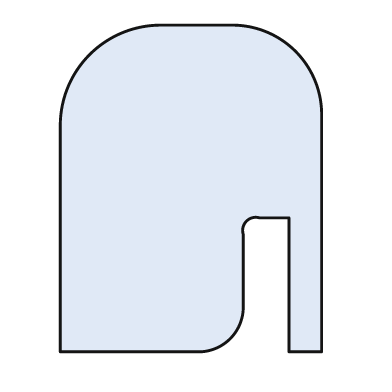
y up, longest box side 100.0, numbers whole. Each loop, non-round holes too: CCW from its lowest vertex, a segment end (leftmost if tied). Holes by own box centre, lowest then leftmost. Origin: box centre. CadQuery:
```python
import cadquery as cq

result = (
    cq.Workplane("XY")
    .moveTo(-40.0, -50.0)
    .lineTo(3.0, -50.0)
    .threePointArc((12.0, -46.0), (16.0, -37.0))
    .lineTo(16.0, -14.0)
    .threePointArc((17.0, -10.0), (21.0, -9.0))
    .lineTo(30.0, -9.0)
    .lineTo(30.0, -50.0)
    .lineTo(40.0, -50.0)
    .lineTo(40.0, 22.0)
    .threePointArc((32.0, 42.0), (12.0, 50.0))
    .lineTo(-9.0, 50.0)
    .threePointArc((-31.0, 41.0), (-40.0, 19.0))
    .close()
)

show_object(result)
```